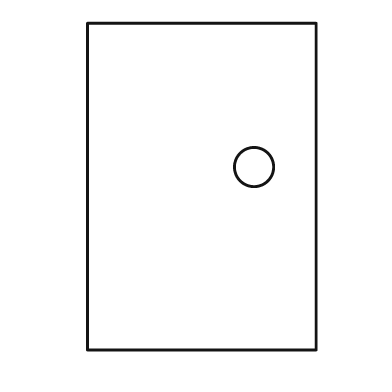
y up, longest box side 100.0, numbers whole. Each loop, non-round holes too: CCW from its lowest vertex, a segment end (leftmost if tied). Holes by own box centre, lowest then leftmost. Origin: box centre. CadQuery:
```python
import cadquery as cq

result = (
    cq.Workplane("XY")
    .moveTo(-35.0, -50.0)
    .lineTo(35.0, -50.0)
    .lineTo(35.0, 50.0)
    .lineTo(-35.0, 50.0)
    .close()
    .moveTo(16.0, 6.0)
    .circle(6.0)
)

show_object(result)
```